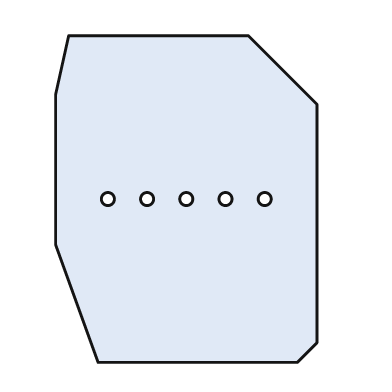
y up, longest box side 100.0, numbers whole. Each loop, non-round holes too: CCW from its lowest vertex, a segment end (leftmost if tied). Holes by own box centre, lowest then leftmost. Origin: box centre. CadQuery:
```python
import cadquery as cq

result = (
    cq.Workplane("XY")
    .moveTo(-27.0, -50.0)
    .lineTo(34.0, -50.0)
    .lineTo(40.0, -44.0)
    .lineTo(40.0, 29.0)
    .lineTo(19.0, 50.0)
    .lineTo(-36.0, 50.0)
    .lineTo(-40.0, 32.0)
    .lineTo(-40.0, -14.0)
    .close()
    .moveTo(-24.0, 0.0)
    .circle(2.0)
    .moveTo(-12.0, 0.0)
    .circle(2.0)
    .moveTo(0.0, 0.0)
    .circle(2.0)
    .moveTo(12.0, 0.0)
    .circle(2.0)
    .moveTo(24.0, 0.0)
    .circle(2.0)
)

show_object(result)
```